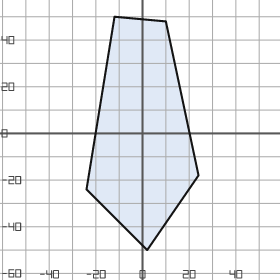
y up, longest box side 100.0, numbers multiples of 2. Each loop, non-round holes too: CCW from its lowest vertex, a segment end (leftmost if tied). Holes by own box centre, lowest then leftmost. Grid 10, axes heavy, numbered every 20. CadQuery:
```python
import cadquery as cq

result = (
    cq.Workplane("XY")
    .moveTo(2.0, -50.0)
    .lineTo(24.0, -18.0)
    .lineTo(10.0, 48.0)
    .lineTo(-12.0, 50.0)
    .lineTo(-24.0, -24.0)
    .close()
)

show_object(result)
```